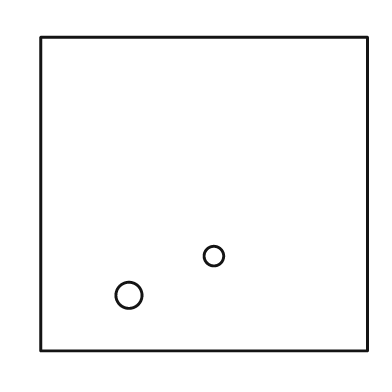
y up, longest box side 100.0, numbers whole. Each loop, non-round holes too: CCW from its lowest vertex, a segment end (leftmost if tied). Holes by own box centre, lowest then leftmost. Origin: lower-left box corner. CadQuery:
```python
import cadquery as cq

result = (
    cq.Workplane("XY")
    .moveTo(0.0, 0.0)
    .lineTo(100.0, 0.0)
    .lineTo(100.0, 96.0)
    .lineTo(0.0, 96.0)
    .close()
    .moveTo(27.0, 17.0)
    .circle(4.0)
    .moveTo(53.0, 29.0)
    .circle(3.0)
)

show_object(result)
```